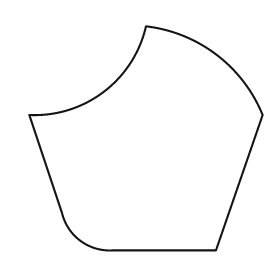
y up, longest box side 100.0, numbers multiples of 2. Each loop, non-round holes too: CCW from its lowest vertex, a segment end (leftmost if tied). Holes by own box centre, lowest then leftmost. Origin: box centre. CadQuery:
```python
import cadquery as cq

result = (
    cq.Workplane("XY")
    .moveTo(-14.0, -48.0)
    .lineTo(30.0, -48.0)
    .lineTo(50.0, 10.0)
    .threePointArc((30.0, 36.0), (0.0, 48.0))
    .threePointArc((-18.0, 20.0), (-50.0, 10.0))
    .lineTo(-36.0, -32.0)
    .threePointArc((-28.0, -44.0), (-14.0, -48.0))
    .close()
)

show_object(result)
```